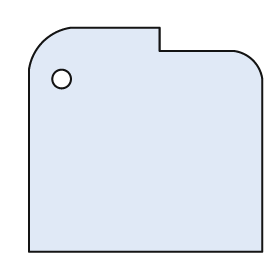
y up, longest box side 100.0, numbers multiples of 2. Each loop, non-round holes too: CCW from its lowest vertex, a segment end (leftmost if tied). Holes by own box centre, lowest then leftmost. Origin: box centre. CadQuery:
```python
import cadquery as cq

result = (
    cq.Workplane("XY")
    .moveTo(-50.0, -48.0)
    .lineTo(50.0, -48.0)
    .lineTo(50.0, 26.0)
    .threePointArc((46.0, 34.0), (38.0, 38.0))
    .lineTo(6.0, 38.0)
    .lineTo(6.0, 48.0)
    .lineTo(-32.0, 48.0)
    .threePointArc((-44.0, 42.0), (-50.0, 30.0))
    .close()
    .moveTo(-36.0, 26.0)
    .circle(4.0)
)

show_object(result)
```